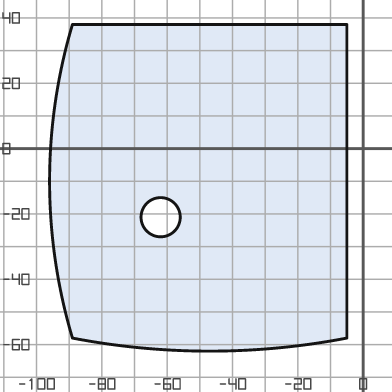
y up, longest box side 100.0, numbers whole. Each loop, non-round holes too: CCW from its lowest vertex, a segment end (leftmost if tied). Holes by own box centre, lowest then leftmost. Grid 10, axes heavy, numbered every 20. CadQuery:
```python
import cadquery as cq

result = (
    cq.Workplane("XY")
    .moveTo(-89.0, -58.0)
    .threePointArc((-47.0, -62.0), (-5.0, -58.0))
    .lineTo(-5.0, 38.0)
    .lineTo(-89.0, 38.0)
    .threePointArc((-96.0, -10.0), (-89.0, -58.0))
    .close()
    .moveTo(-62.0, -21.0)
    .circle(6.0)
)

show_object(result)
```